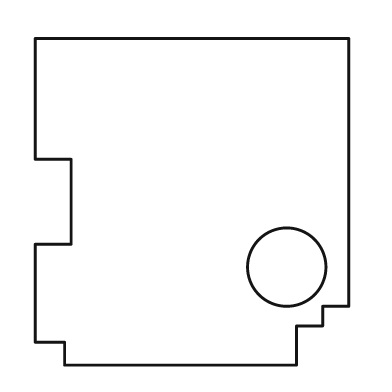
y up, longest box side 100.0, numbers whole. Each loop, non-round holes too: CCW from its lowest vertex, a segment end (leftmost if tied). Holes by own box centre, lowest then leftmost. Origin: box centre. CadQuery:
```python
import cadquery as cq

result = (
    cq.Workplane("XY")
    .moveTo(-39.0, -50.0)
    .lineTo(32.0, -50.0)
    .lineTo(32.0, -38.0)
    .lineTo(40.0, -38.0)
    .lineTo(40.0, -32.0)
    .lineTo(48.0, -32.0)
    .lineTo(48.0, 50.0)
    .lineTo(-48.0, 50.0)
    .lineTo(-48.0, 13.0)
    .lineTo(-37.0, 13.0)
    .lineTo(-37.0, -13.0)
    .lineTo(-48.0, -13.0)
    .lineTo(-48.0, -43.0)
    .lineTo(-39.0, -43.0)
    .close()
    .moveTo(29.0, -20.0)
    .circle(12.0)
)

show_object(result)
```